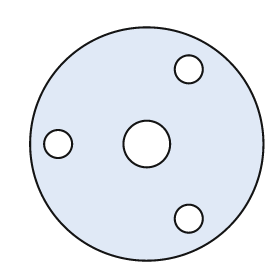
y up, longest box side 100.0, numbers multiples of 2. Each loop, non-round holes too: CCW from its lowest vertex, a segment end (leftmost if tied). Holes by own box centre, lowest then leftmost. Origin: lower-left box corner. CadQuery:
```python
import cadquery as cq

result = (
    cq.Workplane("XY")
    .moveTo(50.0, 50.0)
    .circle(50.0)
    .moveTo(68.0, 18.0)
    .circle(6.0)
    .moveTo(12.0, 50.0)
    .circle(6.0)
    .moveTo(50.0, 50.0)
    .circle(10.0)
    .moveTo(68.0, 82.0)
    .circle(6.0)
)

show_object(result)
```